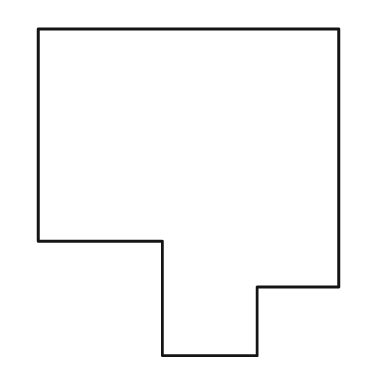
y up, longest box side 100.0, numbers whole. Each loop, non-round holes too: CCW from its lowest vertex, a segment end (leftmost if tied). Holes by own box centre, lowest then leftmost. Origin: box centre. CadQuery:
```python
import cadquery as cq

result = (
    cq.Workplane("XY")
    .moveTo(-8.0, -50.0)
    .lineTo(21.0, -50.0)
    .lineTo(21.0, -29.0)
    .lineTo(46.0, -29.0)
    .lineTo(46.0, 50.0)
    .lineTo(-46.0, 50.0)
    .lineTo(-46.0, -15.0)
    .lineTo(-8.0, -15.0)
    .close()
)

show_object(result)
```